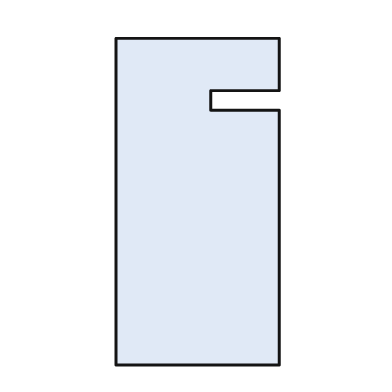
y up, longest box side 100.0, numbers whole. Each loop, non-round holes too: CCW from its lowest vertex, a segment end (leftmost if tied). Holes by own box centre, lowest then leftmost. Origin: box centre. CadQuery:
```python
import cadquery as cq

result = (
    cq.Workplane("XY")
    .moveTo(-25.0, -50.0)
    .lineTo(25.0, -50.0)
    .lineTo(25.0, 28.0)
    .lineTo(4.0, 28.0)
    .lineTo(4.0, 34.0)
    .lineTo(25.0, 34.0)
    .lineTo(25.0, 50.0)
    .lineTo(-25.0, 50.0)
    .close()
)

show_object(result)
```